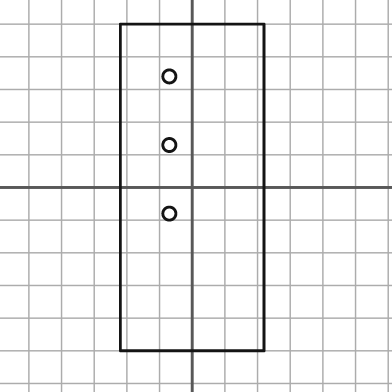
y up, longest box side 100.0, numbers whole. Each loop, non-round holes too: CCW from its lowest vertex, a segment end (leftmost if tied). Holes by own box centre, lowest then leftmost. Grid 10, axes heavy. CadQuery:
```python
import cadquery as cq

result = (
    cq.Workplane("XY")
    .moveTo(-22.0, -50.0)
    .lineTo(22.0, -50.0)
    .lineTo(22.0, 50.0)
    .lineTo(-22.0, 50.0)
    .close()
    .moveTo(-7.0, -8.0)
    .circle(2.0)
    .moveTo(-7.0, 13.0)
    .circle(2.0)
    .moveTo(-7.0, 34.0)
    .circle(2.0)
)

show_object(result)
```